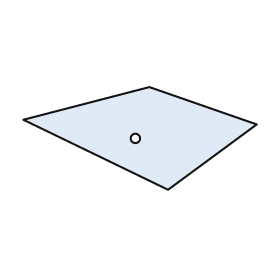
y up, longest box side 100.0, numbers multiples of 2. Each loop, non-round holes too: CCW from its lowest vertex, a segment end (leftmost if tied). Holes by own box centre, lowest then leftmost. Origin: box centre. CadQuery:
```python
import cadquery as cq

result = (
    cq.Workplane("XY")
    .moveTo(12.0, -22.0)
    .lineTo(50.0, 6.0)
    .lineTo(4.0, 22.0)
    .lineTo(-50.0, 8.0)
    .close()
    .moveTo(-2.0, 0.0)
    .circle(2.0)
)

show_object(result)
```